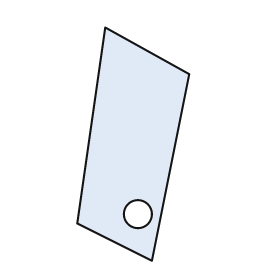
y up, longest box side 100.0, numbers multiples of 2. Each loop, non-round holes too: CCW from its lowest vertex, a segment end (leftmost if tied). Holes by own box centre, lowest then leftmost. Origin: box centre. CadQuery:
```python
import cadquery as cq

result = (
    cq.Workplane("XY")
    .moveTo(8.0, -50.0)
    .lineTo(24.0, 30.0)
    .lineTo(-12.0, 50.0)
    .lineTo(-24.0, -34.0)
    .close()
    .moveTo(2.0, -30.0)
    .circle(6.0)
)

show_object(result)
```